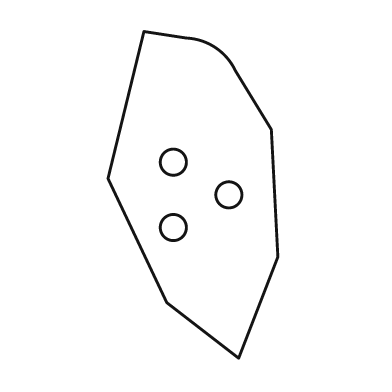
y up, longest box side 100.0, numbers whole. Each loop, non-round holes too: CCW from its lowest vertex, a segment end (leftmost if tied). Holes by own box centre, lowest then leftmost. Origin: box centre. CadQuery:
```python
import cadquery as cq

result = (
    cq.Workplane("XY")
    .moveTo(14.0, -50.0)
    .lineTo(26.0, -19.0)
    .lineTo(24.0, 20.0)
    .lineTo(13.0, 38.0)
    .threePointArc((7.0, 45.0), (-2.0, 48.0))
    .lineTo(-15.0, 50.0)
    .lineTo(-26.0, 5.0)
    .lineTo(-8.0, -33.0)
    .close()
    .moveTo(-6.0, -10.0)
    .circle(4.0)
    .moveTo(11.0, 0.0)
    .circle(4.0)
    .moveTo(-6.0, 10.0)
    .circle(4.0)
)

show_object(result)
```